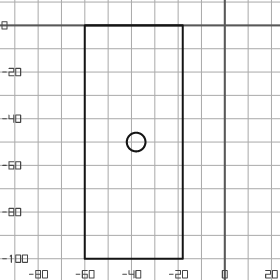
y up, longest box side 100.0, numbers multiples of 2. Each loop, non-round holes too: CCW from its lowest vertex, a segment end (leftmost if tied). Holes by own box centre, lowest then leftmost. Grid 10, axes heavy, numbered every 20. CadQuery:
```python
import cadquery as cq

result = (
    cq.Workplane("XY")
    .moveTo(-60.0, -100.0)
    .lineTo(-18.0, -100.0)
    .lineTo(-18.0, 0.0)
    .lineTo(-60.0, 0.0)
    .close()
    .moveTo(-38.0, -50.0)
    .circle(4.0)
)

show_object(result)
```